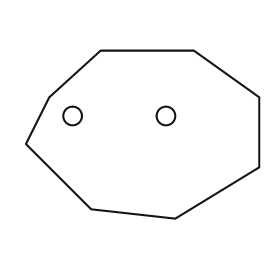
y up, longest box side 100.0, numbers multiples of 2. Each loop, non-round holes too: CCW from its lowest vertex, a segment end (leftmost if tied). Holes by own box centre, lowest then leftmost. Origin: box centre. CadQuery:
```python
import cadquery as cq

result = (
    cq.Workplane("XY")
    .moveTo(14.0, -36.0)
    .lineTo(50.0, -14.0)
    .lineTo(50.0, 16.0)
    .lineTo(22.0, 36.0)
    .lineTo(-18.0, 36.0)
    .lineTo(-40.0, 16.0)
    .lineTo(-50.0, -4.0)
    .lineTo(-22.0, -32.0)
    .close()
    .moveTo(-30.0, 8.0)
    .circle(4.0)
    .moveTo(10.0, 8.0)
    .circle(4.0)
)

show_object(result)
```